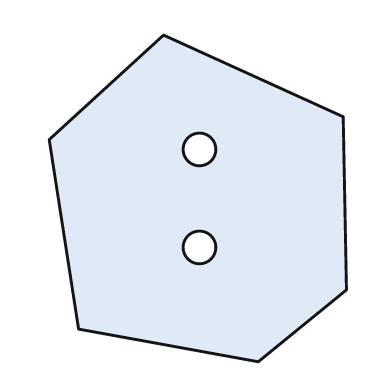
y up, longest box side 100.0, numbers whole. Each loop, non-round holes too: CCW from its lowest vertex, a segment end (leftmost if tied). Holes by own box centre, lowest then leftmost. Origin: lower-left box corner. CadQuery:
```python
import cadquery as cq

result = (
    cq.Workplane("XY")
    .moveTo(64.0, 0.0)
    .lineTo(91.0, 22.0)
    .lineTo(90.0, 75.0)
    .lineTo(35.0, 100.0)
    .lineTo(0.0, 68.0)
    .lineTo(9.0, 10.0)
    .close()
    .moveTo(46.0, 35.0)
    .circle(5.0)
    .moveTo(46.0, 65.0)
    .circle(5.0)
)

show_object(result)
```